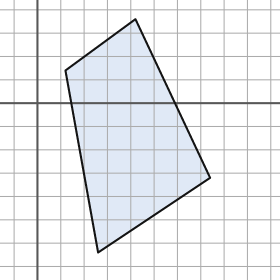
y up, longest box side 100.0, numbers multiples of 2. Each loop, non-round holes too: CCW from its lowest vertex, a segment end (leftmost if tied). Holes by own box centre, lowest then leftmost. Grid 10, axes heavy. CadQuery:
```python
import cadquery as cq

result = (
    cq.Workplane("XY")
    .moveTo(26.0, -64.0)
    .lineTo(74.0, -32.0)
    .lineTo(42.0, 36.0)
    .lineTo(12.0, 14.0)
    .close()
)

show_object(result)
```